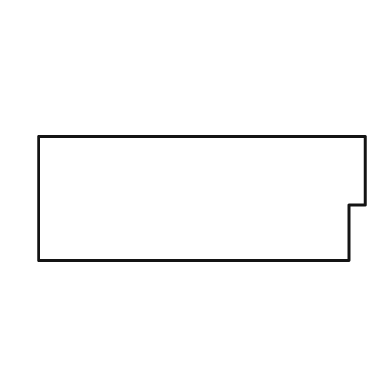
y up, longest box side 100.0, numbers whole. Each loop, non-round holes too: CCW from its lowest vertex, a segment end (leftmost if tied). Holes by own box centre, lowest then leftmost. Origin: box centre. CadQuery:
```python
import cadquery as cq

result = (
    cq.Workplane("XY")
    .moveTo(-50.0, -19.0)
    .lineTo(45.0, -19.0)
    .lineTo(45.0, -2.0)
    .lineTo(50.0, -2.0)
    .lineTo(50.0, 19.0)
    .lineTo(-50.0, 19.0)
    .close()
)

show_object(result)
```